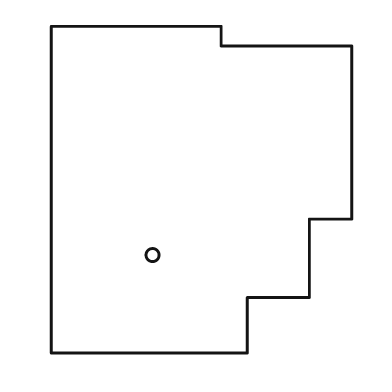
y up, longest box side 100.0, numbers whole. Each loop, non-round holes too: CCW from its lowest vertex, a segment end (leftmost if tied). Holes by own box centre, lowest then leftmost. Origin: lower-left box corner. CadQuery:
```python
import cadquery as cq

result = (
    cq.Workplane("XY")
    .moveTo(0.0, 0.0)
    .lineTo(60.0, 0.0)
    .lineTo(60.0, 17.0)
    .lineTo(79.0, 17.0)
    .lineTo(79.0, 41.0)
    .lineTo(92.0, 41.0)
    .lineTo(92.0, 94.0)
    .lineTo(52.0, 94.0)
    .lineTo(52.0, 100.0)
    .lineTo(0.0, 100.0)
    .close()
    .moveTo(31.0, 30.0)
    .circle(2.0)
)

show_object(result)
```